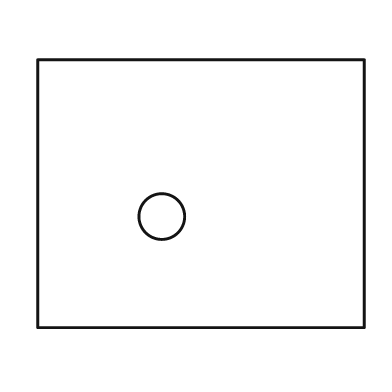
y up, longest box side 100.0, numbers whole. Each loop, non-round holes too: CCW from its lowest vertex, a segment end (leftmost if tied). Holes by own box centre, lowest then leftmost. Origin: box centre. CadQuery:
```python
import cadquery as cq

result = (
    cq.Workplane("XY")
    .moveTo(-50.0, -41.0)
    .lineTo(50.0, -41.0)
    .lineTo(50.0, 41.0)
    .lineTo(-50.0, 41.0)
    .close()
    .moveTo(-12.0, -7.0)
    .circle(7.0)
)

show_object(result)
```